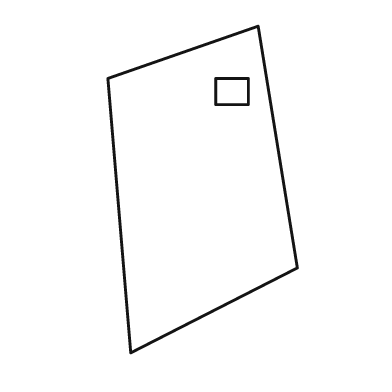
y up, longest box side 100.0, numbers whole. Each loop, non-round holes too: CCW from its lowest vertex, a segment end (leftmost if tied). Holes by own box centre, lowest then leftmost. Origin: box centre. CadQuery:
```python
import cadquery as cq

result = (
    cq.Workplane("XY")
    .moveTo(-22.0, -50.0)
    .lineTo(29.0, -24.0)
    .lineTo(17.0, 50.0)
    .lineTo(-29.0, 34.0)
    .close()
    .moveTo(4.0, 26.0)
    .lineTo(14.0, 26.0)
    .lineTo(14.0, 34.0)
    .lineTo(4.0, 34.0)
    .close()
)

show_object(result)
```